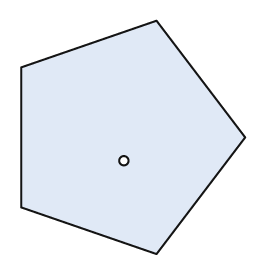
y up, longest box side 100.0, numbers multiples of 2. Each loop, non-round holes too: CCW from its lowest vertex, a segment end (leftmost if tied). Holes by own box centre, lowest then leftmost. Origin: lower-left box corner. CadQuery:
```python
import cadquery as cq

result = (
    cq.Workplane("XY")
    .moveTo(58.0, 0.0)
    .lineTo(96.0, 50.0)
    .lineTo(58.0, 100.0)
    .lineTo(0.0, 80.0)
    .lineTo(0.0, 20.0)
    .close()
    .moveTo(44.0, 40.0)
    .circle(2.0)
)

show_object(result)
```